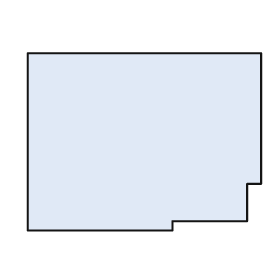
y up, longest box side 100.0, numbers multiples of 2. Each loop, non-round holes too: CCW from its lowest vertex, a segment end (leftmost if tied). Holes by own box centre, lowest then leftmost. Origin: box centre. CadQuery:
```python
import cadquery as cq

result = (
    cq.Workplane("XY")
    .moveTo(-50.0, -38.0)
    .lineTo(12.0, -38.0)
    .lineTo(12.0, -34.0)
    .lineTo(44.0, -34.0)
    .lineTo(44.0, -18.0)
    .lineTo(50.0, -18.0)
    .lineTo(50.0, 38.0)
    .lineTo(-50.0, 38.0)
    .close()
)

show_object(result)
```